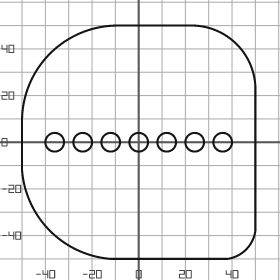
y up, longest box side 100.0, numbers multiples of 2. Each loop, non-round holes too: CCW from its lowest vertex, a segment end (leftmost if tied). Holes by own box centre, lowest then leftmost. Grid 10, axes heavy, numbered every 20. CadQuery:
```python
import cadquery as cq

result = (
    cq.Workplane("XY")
    .moveTo(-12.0, -50.0)
    .lineTo(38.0, -50.0)
    .threePointArc((46.0, -46.0), (50.0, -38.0))
    .lineTo(50.0, 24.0)
    .threePointArc((42.0, 42.0), (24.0, 50.0))
    .lineTo(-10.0, 50.0)
    .threePointArc((-38.0, 38.0), (-50.0, 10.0))
    .lineTo(-50.0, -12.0)
    .threePointArc((-38.0, -38.0), (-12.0, -50.0))
    .close()
    .moveTo(-36.0, 0.0)
    .circle(4.0)
    .moveTo(-24.0, 0.0)
    .circle(4.0)
    .moveTo(-12.0, 0.0)
    .circle(4.0)
    .moveTo(0.0, 0.0)
    .circle(4.0)
    .moveTo(12.0, 0.0)
    .circle(4.0)
    .moveTo(24.0, 0.0)
    .circle(4.0)
    .moveTo(36.0, 0.0)
    .circle(4.0)
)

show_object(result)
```